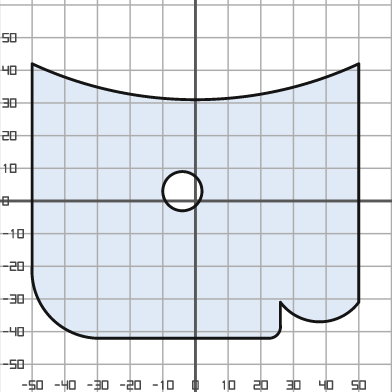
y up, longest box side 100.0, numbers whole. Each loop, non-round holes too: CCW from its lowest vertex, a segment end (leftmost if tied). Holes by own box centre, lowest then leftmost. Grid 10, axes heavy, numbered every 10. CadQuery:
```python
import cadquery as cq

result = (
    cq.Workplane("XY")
    .moveTo(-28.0, -42.0)
    .lineTo(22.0, -42.0)
    .threePointArc((25.0, -41.0), (26.0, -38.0))
    .lineTo(26.0, -31.0)
    .threePointArc((38.0, -37.0), (50.0, -31.0))
    .lineTo(50.0, 42.0)
    .threePointArc((0.0, 31.0), (-50.0, 42.0))
    .lineTo(-50.0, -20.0)
    .threePointArc((-44.0, -36.0), (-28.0, -42.0))
    .close()
    .moveTo(-4.0, 3.0)
    .circle(6.0)
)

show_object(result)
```